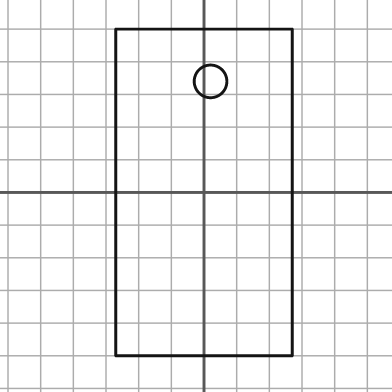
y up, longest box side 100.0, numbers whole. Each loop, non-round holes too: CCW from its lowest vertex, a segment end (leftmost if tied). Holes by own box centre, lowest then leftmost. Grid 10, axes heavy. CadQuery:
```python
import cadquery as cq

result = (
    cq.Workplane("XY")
    .moveTo(-27.0, -50.0)
    .lineTo(27.0, -50.0)
    .lineTo(27.0, 50.0)
    .lineTo(-27.0, 50.0)
    .close()
    .moveTo(2.0, 34.0)
    .circle(5.0)
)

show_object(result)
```